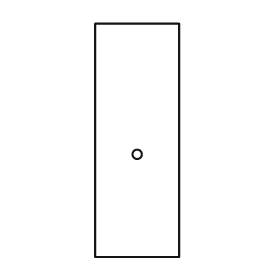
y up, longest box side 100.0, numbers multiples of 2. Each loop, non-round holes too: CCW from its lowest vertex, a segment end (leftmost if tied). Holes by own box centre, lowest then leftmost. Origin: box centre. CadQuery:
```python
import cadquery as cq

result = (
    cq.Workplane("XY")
    .moveTo(-18.0, -50.0)
    .lineTo(18.0, -50.0)
    .lineTo(18.0, 50.0)
    .lineTo(-18.0, 50.0)
    .close()
    .moveTo(0.0, -6.0)
    .circle(2.0)
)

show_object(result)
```